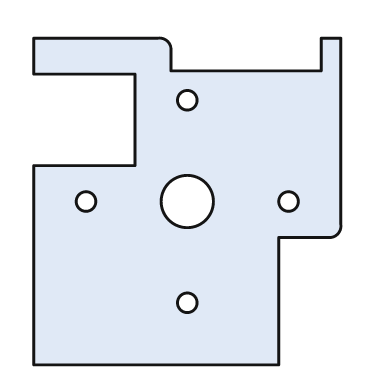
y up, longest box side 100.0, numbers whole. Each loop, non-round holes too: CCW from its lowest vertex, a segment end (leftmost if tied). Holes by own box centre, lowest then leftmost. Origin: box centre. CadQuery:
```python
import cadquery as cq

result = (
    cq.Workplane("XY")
    .moveTo(-47.0, -50.0)
    .lineTo(28.0, -50.0)
    .lineTo(28.0, -11.0)
    .lineTo(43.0, -11.0)
    .threePointArc((46.0, -10.0), (47.0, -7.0))
    .lineTo(47.0, 50.0)
    .lineTo(41.0, 50.0)
    .lineTo(41.0, 40.0)
    .lineTo(-5.0, 40.0)
    .lineTo(-5.0, 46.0)
    .threePointArc((-6.0, 49.0), (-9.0, 50.0))
    .lineTo(-47.0, 50.0)
    .lineTo(-47.0, 39.0)
    .lineTo(-16.0, 39.0)
    .lineTo(-16.0, 11.0)
    .lineTo(-47.0, 11.0)
    .close()
    .moveTo(0.0, -31.0)
    .circle(3.0)
    .moveTo(-31.0, 0.0)
    .circle(3.0)
    .moveTo(0.0, 0.0)
    .circle(8.0)
    .moveTo(31.0, 0.0)
    .circle(3.0)
    .moveTo(0.0, 31.0)
    .circle(3.0)
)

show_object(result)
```